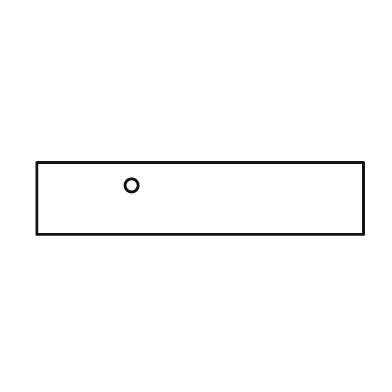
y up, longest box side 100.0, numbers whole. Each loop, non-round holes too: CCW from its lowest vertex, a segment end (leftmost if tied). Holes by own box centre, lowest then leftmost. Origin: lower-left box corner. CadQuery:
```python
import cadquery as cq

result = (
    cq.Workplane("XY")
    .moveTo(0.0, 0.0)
    .lineTo(100.0, 0.0)
    .lineTo(100.0, 22.0)
    .lineTo(0.0, 22.0)
    .close()
    .moveTo(29.0, 15.0)
    .circle(2.0)
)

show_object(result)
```